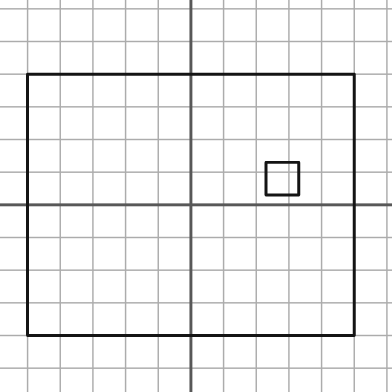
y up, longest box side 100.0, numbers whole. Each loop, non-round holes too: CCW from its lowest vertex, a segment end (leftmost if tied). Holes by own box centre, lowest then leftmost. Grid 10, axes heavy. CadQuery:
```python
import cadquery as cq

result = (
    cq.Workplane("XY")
    .moveTo(-50.0, -40.0)
    .lineTo(50.0, -40.0)
    .lineTo(50.0, 40.0)
    .lineTo(-50.0, 40.0)
    .close()
    .moveTo(23.0, 3.0)
    .lineTo(33.0, 3.0)
    .lineTo(33.0, 13.0)
    .lineTo(23.0, 13.0)
    .close()
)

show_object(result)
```